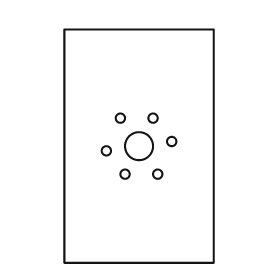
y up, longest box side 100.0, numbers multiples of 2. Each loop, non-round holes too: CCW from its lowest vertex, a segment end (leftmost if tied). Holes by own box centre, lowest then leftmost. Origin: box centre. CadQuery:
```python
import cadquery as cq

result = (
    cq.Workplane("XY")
    .moveTo(-32.0, -50.0)
    .lineTo(32.0, -50.0)
    .lineTo(32.0, 50.0)
    .lineTo(-32.0, 50.0)
    .close()
    .moveTo(-6.0, -12.0)
    .circle(2.0)
    .moveTo(8.0, -12.0)
    .circle(2.0)
    .moveTo(-14.0, -2.0)
    .circle(2.0)
    .moveTo(0.0, 0.0)
    .circle(6.0)
    .moveTo(14.0, 2.0)
    .circle(2.0)
    .moveTo(-8.0, 12.0)
    .circle(2.0)
    .moveTo(6.0, 12.0)
    .circle(2.0)
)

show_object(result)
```